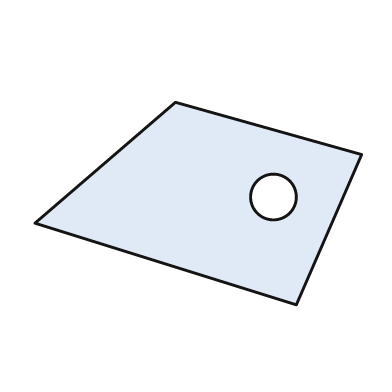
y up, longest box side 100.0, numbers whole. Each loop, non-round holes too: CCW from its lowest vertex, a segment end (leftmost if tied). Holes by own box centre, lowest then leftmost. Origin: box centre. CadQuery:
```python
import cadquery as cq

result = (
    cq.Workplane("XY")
    .moveTo(30.0, -31.0)
    .lineTo(50.0, 15.0)
    .lineTo(-7.0, 31.0)
    .lineTo(-50.0, -6.0)
    .close()
    .moveTo(23.0, 2.0)
    .circle(7.0)
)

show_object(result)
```